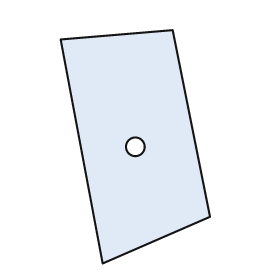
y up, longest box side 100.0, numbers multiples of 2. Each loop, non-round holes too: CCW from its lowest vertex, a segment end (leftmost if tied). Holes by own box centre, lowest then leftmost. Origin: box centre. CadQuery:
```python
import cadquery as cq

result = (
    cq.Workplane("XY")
    .moveTo(-14.0, -50.0)
    .lineTo(32.0, -30.0)
    .lineTo(16.0, 50.0)
    .lineTo(-32.0, 46.0)
    .close()
    .moveTo(0.0, 0.0)
    .circle(4.0)
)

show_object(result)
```